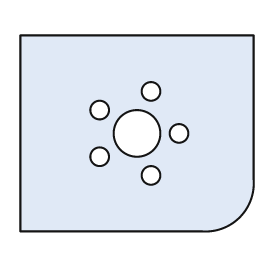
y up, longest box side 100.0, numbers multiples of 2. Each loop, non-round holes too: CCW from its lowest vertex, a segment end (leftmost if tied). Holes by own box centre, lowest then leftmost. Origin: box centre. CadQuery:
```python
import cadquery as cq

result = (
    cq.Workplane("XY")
    .moveTo(-50.0, -42.0)
    .lineTo(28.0, -42.0)
    .threePointArc((44.0, -36.0), (50.0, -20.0))
    .lineTo(50.0, 42.0)
    .lineTo(-50.0, 42.0)
    .close()
    .moveTo(6.0, -18.0)
    .circle(4.0)
    .moveTo(-16.0, -10.0)
    .circle(4.0)
    .moveTo(0.0, 0.0)
    .circle(10.0)
    .moveTo(18.0, 0.0)
    .circle(4.0)
    .moveTo(-16.0, 10.0)
    .circle(4.0)
    .moveTo(6.0, 18.0)
    .circle(4.0)
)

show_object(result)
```